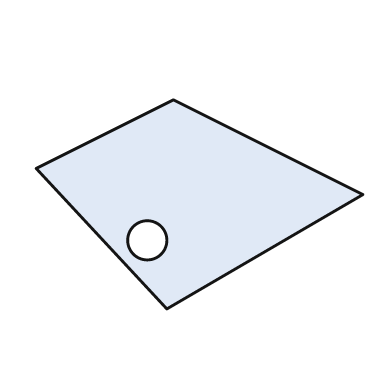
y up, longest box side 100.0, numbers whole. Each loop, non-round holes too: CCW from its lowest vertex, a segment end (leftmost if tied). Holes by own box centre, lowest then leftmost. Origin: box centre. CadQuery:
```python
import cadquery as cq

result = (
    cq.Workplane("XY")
    .moveTo(-10.0, -32.0)
    .lineTo(50.0, 3.0)
    .lineTo(-8.0, 32.0)
    .lineTo(-50.0, 11.0)
    .close()
    .moveTo(-16.0, -11.0)
    .circle(6.0)
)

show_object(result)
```